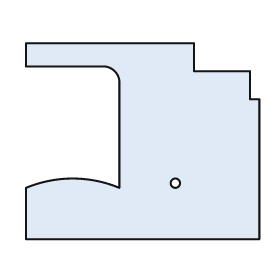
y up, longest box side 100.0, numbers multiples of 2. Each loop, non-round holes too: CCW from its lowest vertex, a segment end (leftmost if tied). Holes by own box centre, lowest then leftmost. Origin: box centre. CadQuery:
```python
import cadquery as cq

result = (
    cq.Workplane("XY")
    .moveTo(-50.0, -42.0)
    .lineTo(50.0, -42.0)
    .lineTo(50.0, 18.0)
    .lineTo(46.0, 18.0)
    .lineTo(46.0, 30.0)
    .lineTo(22.0, 30.0)
    .lineTo(22.0, 42.0)
    .lineTo(-50.0, 42.0)
    .lineTo(-50.0, 32.0)
    .lineTo(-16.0, 32.0)
    .threePointArc((-12.0, 30.0), (-10.0, 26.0))
    .lineTo(-10.0, -20.0)
    .threePointArc((-30.0, -16.0), (-50.0, -20.0))
    .close()
    .moveTo(14.0, -18.0)
    .circle(2.0)
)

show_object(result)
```